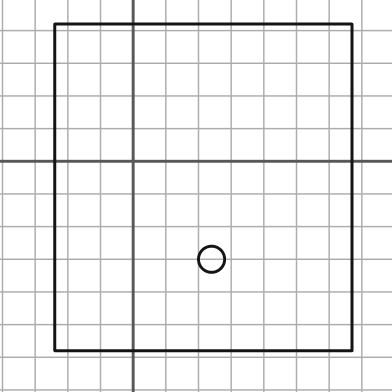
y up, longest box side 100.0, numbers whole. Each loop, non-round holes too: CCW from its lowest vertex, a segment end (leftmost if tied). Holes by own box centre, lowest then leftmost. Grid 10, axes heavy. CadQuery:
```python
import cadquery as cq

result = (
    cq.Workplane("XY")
    .moveTo(-24.0, -58.0)
    .lineTo(67.0, -58.0)
    .lineTo(67.0, 42.0)
    .lineTo(-24.0, 42.0)
    .close()
    .moveTo(24.0, -30.0)
    .circle(4.0)
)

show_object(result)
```